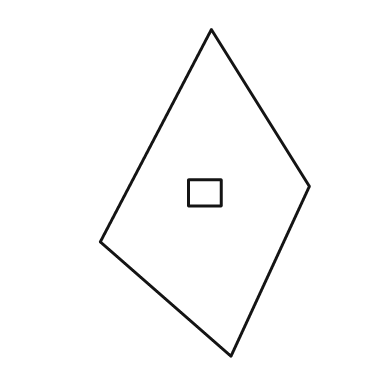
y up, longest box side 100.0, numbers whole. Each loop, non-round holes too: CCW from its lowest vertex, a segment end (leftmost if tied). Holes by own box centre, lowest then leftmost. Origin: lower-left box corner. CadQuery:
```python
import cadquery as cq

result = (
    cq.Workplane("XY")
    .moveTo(40.0, 0.0)
    .lineTo(64.0, 52.0)
    .lineTo(34.0, 100.0)
    .lineTo(0.0, 35.0)
    .close()
    .moveTo(27.0, 46.0)
    .lineTo(37.0, 46.0)
    .lineTo(37.0, 54.0)
    .lineTo(27.0, 54.0)
    .close()
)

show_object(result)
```